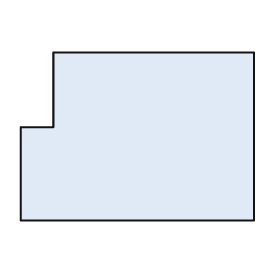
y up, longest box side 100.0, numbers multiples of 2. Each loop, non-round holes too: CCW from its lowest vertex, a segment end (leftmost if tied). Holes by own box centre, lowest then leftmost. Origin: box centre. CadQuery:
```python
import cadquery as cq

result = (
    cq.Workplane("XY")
    .moveTo(-50.0, -36.0)
    .lineTo(50.0, -36.0)
    .lineTo(50.0, 36.0)
    .lineTo(-36.0, 36.0)
    .lineTo(-36.0, 4.0)
    .lineTo(-50.0, 4.0)
    .close()
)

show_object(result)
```